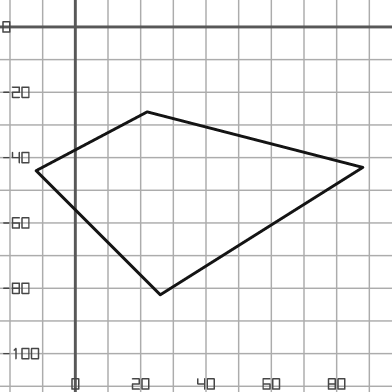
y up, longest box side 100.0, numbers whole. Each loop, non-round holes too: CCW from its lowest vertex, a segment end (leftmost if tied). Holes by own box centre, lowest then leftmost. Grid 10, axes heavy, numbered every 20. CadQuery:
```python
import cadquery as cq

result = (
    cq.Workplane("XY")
    .moveTo(26.0, -82.0)
    .lineTo(88.0, -43.0)
    .lineTo(22.0, -26.0)
    .lineTo(-12.0, -44.0)
    .close()
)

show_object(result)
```